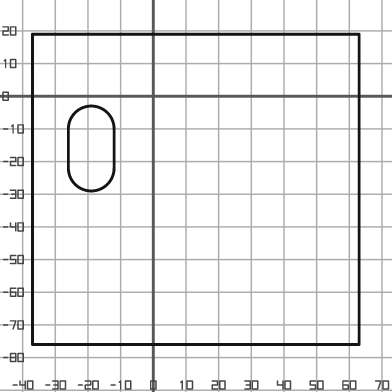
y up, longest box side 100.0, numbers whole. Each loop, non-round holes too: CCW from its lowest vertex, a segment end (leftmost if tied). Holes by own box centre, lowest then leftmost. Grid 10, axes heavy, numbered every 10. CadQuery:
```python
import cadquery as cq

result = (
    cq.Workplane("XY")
    .moveTo(-37.0, -76.0)
    .lineTo(63.0, -76.0)
    .lineTo(63.0, 19.0)
    .lineTo(-37.0, 19.0)
    .close()
    .moveTo(-26.0, -22.0)
    .threePointArc((-19.0, -29.0), (-12.0, -22.0))
    .lineTo(-12.0, -10.0)
    .threePointArc((-19.0, -3.0), (-26.0, -10.0))
    .close()
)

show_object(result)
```